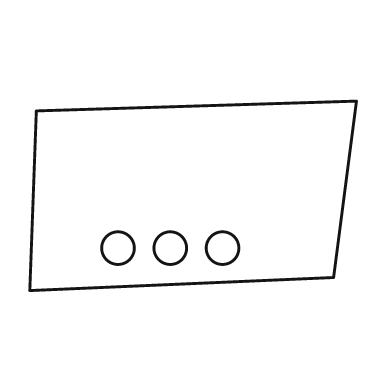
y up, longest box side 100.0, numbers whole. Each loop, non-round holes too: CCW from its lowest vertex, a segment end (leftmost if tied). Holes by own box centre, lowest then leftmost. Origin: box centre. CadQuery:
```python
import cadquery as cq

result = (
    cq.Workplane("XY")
    .moveTo(-50.0, -29.0)
    .lineTo(43.0, -25.0)
    .lineTo(50.0, 29.0)
    .lineTo(-48.0, 26.0)
    .close()
    .moveTo(-23.0, -16.0)
    .circle(5.0)
    .moveTo(-7.0, -16.0)
    .circle(5.0)
    .moveTo(9.0, -16.0)
    .circle(5.0)
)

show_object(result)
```